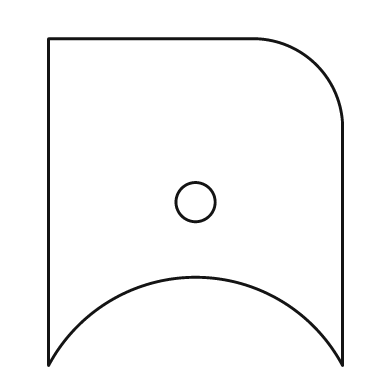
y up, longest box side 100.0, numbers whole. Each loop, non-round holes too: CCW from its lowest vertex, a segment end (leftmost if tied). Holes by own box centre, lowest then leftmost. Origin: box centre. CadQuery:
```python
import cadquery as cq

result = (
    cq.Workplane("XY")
    .moveTo(-45.0, -50.0)
    .threePointArc((0.0, -23.0), (45.0, -50.0))
    .lineTo(45.0, 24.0)
    .threePointArc((37.0, 42.0), (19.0, 50.0))
    .lineTo(-45.0, 50.0)
    .close()
    .moveTo(0.0, 0.0)
    .circle(6.0)
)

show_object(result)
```